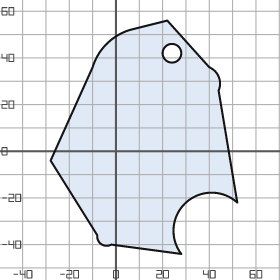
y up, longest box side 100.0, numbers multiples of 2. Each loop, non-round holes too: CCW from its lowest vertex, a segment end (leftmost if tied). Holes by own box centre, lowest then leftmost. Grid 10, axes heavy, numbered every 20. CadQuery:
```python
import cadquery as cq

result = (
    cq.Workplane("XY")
    .moveTo(28.0, -44.0)
    .threePointArc((30.0, -22.0), (52.0, -22.0))
    .lineTo(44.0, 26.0)
    .threePointArc((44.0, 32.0), (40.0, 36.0))
    .lineTo(22.0, 56.0)
    .lineTo(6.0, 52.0)
    .threePointArc((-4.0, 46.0), (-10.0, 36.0))
    .lineTo(-28.0, -4.0)
    .lineTo(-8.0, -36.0)
    .threePointArc((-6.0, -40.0), (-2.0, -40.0))
    .close()
    .moveTo(24.0, 42.0)
    .circle(4.0)
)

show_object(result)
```